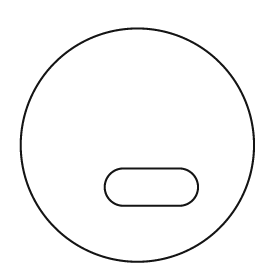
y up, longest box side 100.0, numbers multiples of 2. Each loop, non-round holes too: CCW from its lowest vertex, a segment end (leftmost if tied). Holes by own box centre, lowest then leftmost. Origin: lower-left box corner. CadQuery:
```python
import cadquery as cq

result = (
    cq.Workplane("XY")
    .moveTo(50.0, 50.0)
    .circle(50.0)
    .moveTo(44.0, 24.0)
    .lineTo(68.0, 24.0)
    .threePointArc((76.0, 32.0), (68.0, 40.0))
    .lineTo(44.0, 40.0)
    .threePointArc((36.0, 32.0), (44.0, 24.0))
    .close()
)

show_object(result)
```